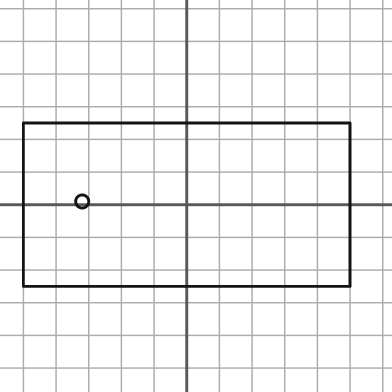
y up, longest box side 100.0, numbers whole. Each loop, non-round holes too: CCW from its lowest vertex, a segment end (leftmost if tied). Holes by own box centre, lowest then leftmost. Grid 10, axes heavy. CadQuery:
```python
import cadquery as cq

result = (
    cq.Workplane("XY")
    .moveTo(-50.0, -25.0)
    .lineTo(50.0, -25.0)
    .lineTo(50.0, 25.0)
    .lineTo(-50.0, 25.0)
    .close()
    .moveTo(-32.0, 1.0)
    .circle(2.0)
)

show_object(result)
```